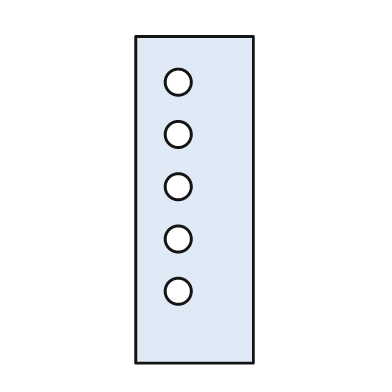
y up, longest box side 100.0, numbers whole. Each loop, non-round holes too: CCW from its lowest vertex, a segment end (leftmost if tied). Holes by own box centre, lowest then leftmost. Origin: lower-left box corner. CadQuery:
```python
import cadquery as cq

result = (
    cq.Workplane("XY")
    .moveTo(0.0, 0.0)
    .lineTo(36.0, 0.0)
    .lineTo(36.0, 100.0)
    .lineTo(0.0, 100.0)
    .close()
    .moveTo(13.0, 22.0)
    .circle(4.0)
    .moveTo(13.0, 38.0)
    .circle(4.0)
    .moveTo(13.0, 54.0)
    .circle(4.0)
    .moveTo(13.0, 70.0)
    .circle(4.0)
    .moveTo(13.0, 86.0)
    .circle(4.0)
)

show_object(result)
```